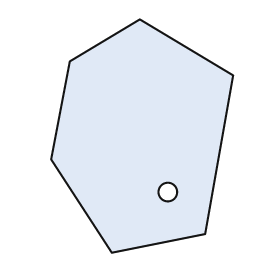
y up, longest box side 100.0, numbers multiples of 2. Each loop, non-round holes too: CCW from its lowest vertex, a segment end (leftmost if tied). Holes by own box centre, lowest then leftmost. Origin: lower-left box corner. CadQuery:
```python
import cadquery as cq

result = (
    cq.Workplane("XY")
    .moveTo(26.0, 0.0)
    .lineTo(66.0, 8.0)
    .lineTo(78.0, 76.0)
    .lineTo(38.0, 100.0)
    .lineTo(8.0, 82.0)
    .lineTo(0.0, 40.0)
    .close()
    .moveTo(50.0, 26.0)
    .circle(4.0)
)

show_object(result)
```